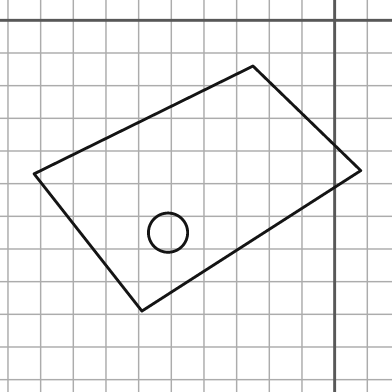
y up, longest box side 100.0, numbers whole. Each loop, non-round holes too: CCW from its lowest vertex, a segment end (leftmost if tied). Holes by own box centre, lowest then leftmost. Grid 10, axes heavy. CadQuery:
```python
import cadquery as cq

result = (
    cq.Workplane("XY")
    .moveTo(-59.0, -89.0)
    .lineTo(8.0, -46.0)
    .lineTo(-25.0, -14.0)
    .lineTo(-92.0, -47.0)
    .close()
    .moveTo(-51.0, -65.0)
    .circle(6.0)
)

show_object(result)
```